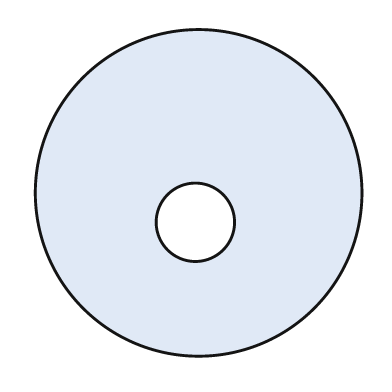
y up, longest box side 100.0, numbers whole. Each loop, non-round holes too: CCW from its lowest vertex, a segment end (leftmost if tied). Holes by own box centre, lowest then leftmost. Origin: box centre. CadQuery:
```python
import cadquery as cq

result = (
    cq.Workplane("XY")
    .moveTo(0.0, 0.0)
    .circle(50.0)
    .moveTo(-1.0, -9.0)
    .circle(12.0)
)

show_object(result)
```